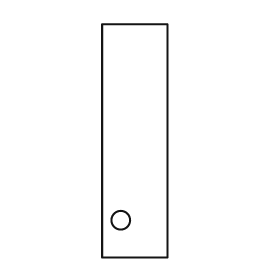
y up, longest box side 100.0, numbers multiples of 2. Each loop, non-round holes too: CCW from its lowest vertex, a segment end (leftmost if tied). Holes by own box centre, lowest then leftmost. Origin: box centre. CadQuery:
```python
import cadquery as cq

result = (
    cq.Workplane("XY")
    .moveTo(-14.0, -50.0)
    .lineTo(14.0, -50.0)
    .lineTo(14.0, 50.0)
    .lineTo(-14.0, 50.0)
    .close()
    .moveTo(-6.0, -34.0)
    .circle(4.0)
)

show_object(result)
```